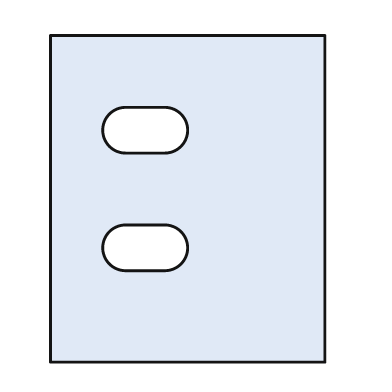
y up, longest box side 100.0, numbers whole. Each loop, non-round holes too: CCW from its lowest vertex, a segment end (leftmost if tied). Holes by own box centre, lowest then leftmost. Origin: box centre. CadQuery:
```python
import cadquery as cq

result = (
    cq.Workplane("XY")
    .moveTo(-42.0, -50.0)
    .lineTo(42.0, -50.0)
    .lineTo(42.0, 50.0)
    .lineTo(-42.0, 50.0)
    .close()
    .moveTo(-19.0, -22.0)
    .lineTo(-7.0, -22.0)
    .threePointArc((0.0, -15.0), (-7.0, -8.0))
    .lineTo(-19.0, -8.0)
    .threePointArc((-26.0, -15.0), (-19.0, -22.0))
    .close()
    .moveTo(-19.0, 14.0)
    .lineTo(-7.0, 14.0)
    .threePointArc((0.0, 21.0), (-7.0, 28.0))
    .lineTo(-19.0, 28.0)
    .threePointArc((-26.0, 21.0), (-19.0, 14.0))
    .close()
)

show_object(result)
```